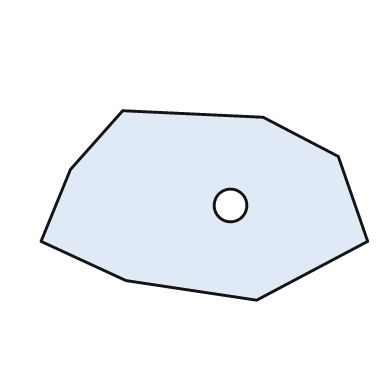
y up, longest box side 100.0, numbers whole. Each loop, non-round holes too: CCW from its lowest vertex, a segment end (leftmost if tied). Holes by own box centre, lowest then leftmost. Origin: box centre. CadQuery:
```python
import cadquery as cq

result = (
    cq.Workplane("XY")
    .moveTo(16.0, -29.0)
    .lineTo(50.0, -11.0)
    .lineTo(41.0, 15.0)
    .lineTo(18.0, 27.0)
    .lineTo(-25.0, 29.0)
    .lineTo(-41.0, 11.0)
    .lineTo(-50.0, -11.0)
    .lineTo(-24.0, -23.0)
    .close()
    .moveTo(8.0, 0.0)
    .circle(5.0)
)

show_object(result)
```